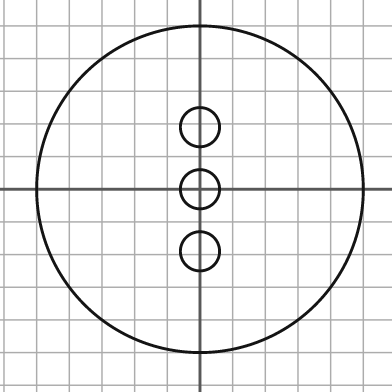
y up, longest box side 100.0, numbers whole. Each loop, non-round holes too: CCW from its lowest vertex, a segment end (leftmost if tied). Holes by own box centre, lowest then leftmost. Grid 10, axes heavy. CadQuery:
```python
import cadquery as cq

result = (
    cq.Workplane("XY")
    .moveTo(0.0, 0.0)
    .circle(50.0)
    .moveTo(0.0, -19.0)
    .circle(6.0)
    .moveTo(0.0, 0.0)
    .circle(6.0)
    .moveTo(0.0, 19.0)
    .circle(6.0)
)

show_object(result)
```